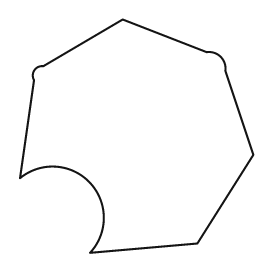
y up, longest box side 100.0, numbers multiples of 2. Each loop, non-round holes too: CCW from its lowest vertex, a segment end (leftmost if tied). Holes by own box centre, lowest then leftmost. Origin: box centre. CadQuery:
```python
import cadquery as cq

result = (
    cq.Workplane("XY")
    .moveTo(-20.0, -50.0)
    .lineTo(26.0, -46.0)
    .lineTo(50.0, -8.0)
    .lineTo(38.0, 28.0)
    .threePointArc((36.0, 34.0), (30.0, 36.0))
    .lineTo(-6.0, 50.0)
    .lineTo(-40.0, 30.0)
    .threePointArc((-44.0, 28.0), (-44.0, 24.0))
    .lineTo(-50.0, -18.0)
    .threePointArc((-20.0, -20.0), (-20.0, -50.0))
    .close()
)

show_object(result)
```